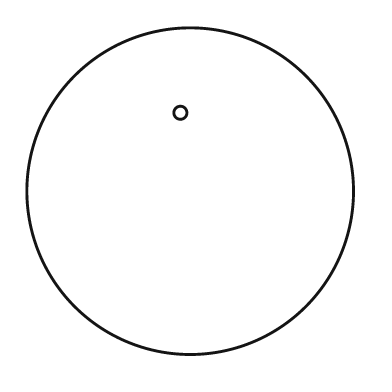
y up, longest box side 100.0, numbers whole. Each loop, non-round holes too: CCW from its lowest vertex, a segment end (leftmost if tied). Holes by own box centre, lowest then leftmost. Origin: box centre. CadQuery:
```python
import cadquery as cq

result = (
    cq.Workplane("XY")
    .moveTo(0.0, 0.0)
    .circle(50.0)
    .moveTo(-3.0, 24.0)
    .circle(2.0)
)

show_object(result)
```